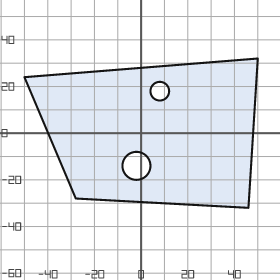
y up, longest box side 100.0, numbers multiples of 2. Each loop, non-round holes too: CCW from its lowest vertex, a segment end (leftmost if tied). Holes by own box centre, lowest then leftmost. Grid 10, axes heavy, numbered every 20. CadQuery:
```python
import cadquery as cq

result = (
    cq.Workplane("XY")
    .moveTo(46.0, -32.0)
    .lineTo(50.0, 32.0)
    .lineTo(-50.0, 24.0)
    .lineTo(-28.0, -28.0)
    .close()
    .moveTo(-2.0, -14.0)
    .circle(6.0)
    .moveTo(8.0, 18.0)
    .circle(4.0)
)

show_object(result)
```